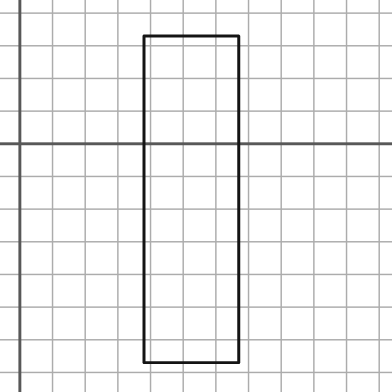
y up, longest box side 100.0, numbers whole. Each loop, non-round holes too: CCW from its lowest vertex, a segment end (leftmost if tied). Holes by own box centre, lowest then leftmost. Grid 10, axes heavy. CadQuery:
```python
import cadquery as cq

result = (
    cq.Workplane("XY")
    .moveTo(38.0, -67.0)
    .lineTo(67.0, -67.0)
    .lineTo(67.0, 33.0)
    .lineTo(38.0, 33.0)
    .close()
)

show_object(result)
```